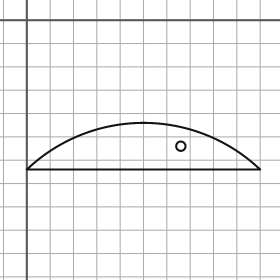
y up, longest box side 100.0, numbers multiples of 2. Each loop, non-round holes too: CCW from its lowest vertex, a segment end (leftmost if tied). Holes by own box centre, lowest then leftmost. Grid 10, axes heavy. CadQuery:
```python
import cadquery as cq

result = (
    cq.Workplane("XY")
    .moveTo(0.0, -64.0)
    .lineTo(100.0, -64.0)
    .threePointArc((50.0, -44.0), (0.0, -64.0))
    .close()
    .moveTo(66.0, -54.0)
    .circle(2.0)
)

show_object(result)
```